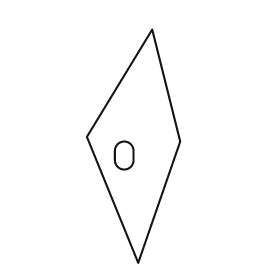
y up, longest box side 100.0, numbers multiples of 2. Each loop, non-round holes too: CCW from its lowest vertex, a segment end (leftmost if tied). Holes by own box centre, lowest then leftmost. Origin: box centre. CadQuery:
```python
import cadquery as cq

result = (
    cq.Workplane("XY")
    .moveTo(2.0, -50.0)
    .lineTo(20.0, 2.0)
    .lineTo(8.0, 50.0)
    .lineTo(-20.0, 4.0)
    .close()
    .moveTo(-8.0, -6.0)
    .threePointArc((-4.0, -10.0), (0.0, -6.0))
    .lineTo(0.0, -2.0)
    .threePointArc((-4.0, 2.0), (-8.0, -2.0))
    .close()
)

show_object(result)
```